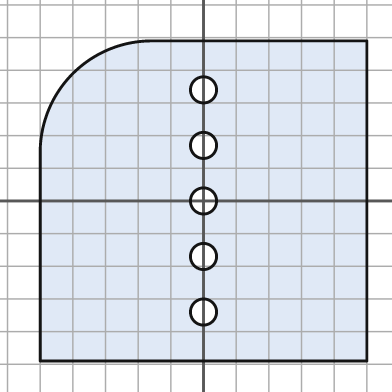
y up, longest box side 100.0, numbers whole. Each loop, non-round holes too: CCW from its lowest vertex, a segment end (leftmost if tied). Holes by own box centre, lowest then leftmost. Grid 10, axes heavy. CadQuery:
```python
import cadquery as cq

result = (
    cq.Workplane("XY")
    .moveTo(-50.0, -49.0)
    .lineTo(50.0, -49.0)
    .lineTo(50.0, 49.0)
    .lineTo(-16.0, 49.0)
    .threePointArc((-40.0, 39.0), (-50.0, 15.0))
    .close()
    .moveTo(0.0, -34.0)
    .circle(4.0)
    .moveTo(0.0, -17.0)
    .circle(4.0)
    .moveTo(0.0, 0.0)
    .circle(4.0)
    .moveTo(0.0, 17.0)
    .circle(4.0)
    .moveTo(0.0, 34.0)
    .circle(4.0)
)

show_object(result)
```